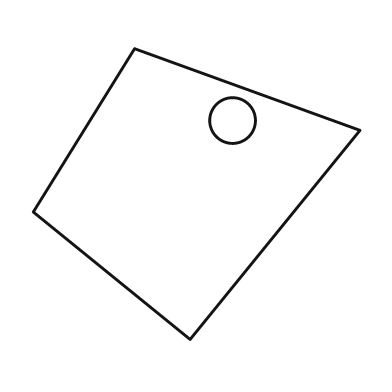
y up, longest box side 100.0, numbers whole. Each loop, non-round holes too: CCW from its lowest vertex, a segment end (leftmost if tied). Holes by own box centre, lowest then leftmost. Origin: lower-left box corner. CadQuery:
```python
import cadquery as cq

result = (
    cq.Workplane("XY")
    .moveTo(48.0, 0.0)
    .lineTo(100.0, 64.0)
    .lineTo(31.0, 89.0)
    .lineTo(0.0, 39.0)
    .close()
    .moveTo(61.0, 67.0)
    .circle(7.0)
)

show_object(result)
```